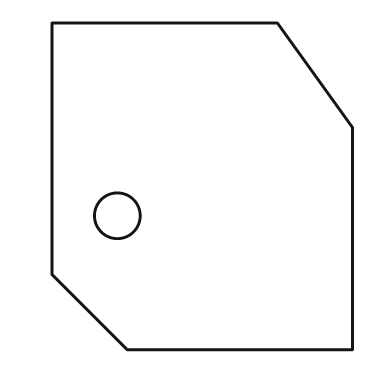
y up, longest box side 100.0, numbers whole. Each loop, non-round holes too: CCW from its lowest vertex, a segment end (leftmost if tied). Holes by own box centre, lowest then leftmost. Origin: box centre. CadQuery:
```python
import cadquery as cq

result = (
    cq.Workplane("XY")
    .moveTo(-23.0, -50.0)
    .lineTo(46.0, -50.0)
    .lineTo(46.0, 18.0)
    .lineTo(23.0, 50.0)
    .lineTo(-46.0, 50.0)
    .lineTo(-46.0, -27.0)
    .close()
    .moveTo(-26.0, -9.0)
    .circle(7.0)
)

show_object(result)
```